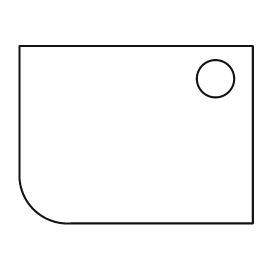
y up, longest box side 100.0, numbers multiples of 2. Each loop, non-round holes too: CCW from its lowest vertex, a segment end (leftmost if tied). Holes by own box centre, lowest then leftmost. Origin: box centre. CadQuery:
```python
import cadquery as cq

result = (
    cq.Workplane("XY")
    .moveTo(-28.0, -38.0)
    .lineTo(50.0, -38.0)
    .lineTo(50.0, 38.0)
    .lineTo(-50.0, 38.0)
    .lineTo(-50.0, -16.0)
    .threePointArc((-44.0, -32.0), (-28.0, -38.0))
    .close()
    .moveTo(34.0, 24.0)
    .circle(8.0)
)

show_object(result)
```